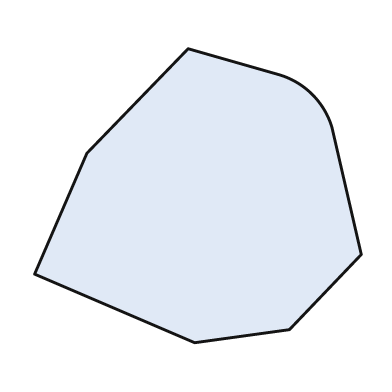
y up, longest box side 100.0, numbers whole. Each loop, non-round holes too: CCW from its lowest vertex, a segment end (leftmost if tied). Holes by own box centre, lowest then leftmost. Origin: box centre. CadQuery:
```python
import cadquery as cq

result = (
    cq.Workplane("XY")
    .moveTo(-1.0, -45.0)
    .lineTo(28.0, -41.0)
    .lineTo(50.0, -18.0)
    .lineTo(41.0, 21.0)
    .threePointArc((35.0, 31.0), (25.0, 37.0))
    .lineTo(-3.0, 45.0)
    .lineTo(-34.0, 13.0)
    .lineTo(-50.0, -24.0)
    .close()
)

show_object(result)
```